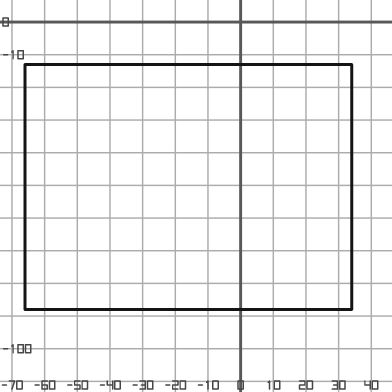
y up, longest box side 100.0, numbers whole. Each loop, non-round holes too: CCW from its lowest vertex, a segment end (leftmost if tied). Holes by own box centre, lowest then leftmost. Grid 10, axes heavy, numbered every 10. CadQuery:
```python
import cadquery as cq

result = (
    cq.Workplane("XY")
    .moveTo(-66.0, -88.0)
    .lineTo(34.0, -88.0)
    .lineTo(34.0, -13.0)
    .lineTo(-66.0, -13.0)
    .close()
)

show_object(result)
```